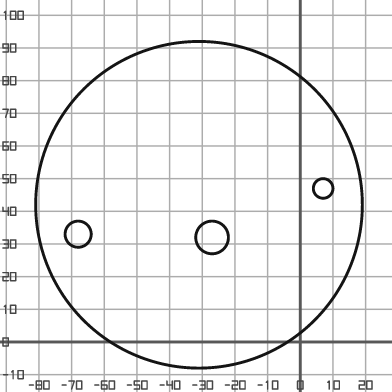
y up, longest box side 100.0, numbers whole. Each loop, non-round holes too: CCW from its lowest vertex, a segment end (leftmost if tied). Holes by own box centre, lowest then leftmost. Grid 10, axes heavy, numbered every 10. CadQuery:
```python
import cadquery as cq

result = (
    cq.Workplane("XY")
    .moveTo(-31.0, 42.0)
    .circle(50.0)
    .moveTo(-27.0, 32.0)
    .circle(5.0)
    .moveTo(-68.0, 33.0)
    .circle(4.0)
    .moveTo(7.0, 47.0)
    .circle(3.0)
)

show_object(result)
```